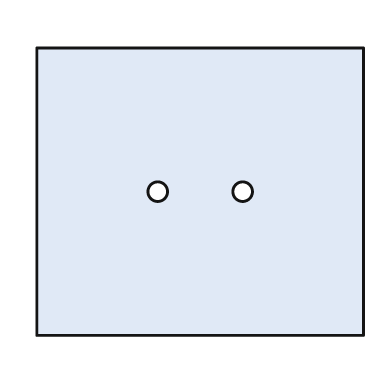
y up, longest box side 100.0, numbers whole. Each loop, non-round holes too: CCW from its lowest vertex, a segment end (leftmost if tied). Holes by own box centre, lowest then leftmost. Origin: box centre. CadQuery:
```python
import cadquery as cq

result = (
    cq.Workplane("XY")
    .moveTo(-50.0, -44.0)
    .lineTo(50.0, -44.0)
    .lineTo(50.0, 44.0)
    .lineTo(-50.0, 44.0)
    .close()
    .moveTo(-13.0, 0.0)
    .circle(3.0)
    .moveTo(13.0, 0.0)
    .circle(3.0)
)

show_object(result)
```